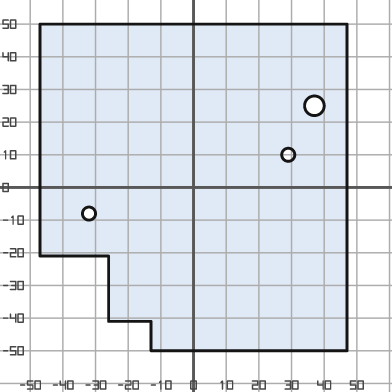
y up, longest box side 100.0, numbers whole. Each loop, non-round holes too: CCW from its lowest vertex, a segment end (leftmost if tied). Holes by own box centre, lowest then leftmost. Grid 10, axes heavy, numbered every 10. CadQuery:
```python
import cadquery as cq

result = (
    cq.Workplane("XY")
    .moveTo(-13.0, -50.0)
    .lineTo(47.0, -50.0)
    .lineTo(47.0, 50.0)
    .lineTo(-47.0, 50.0)
    .lineTo(-47.0, -21.0)
    .lineTo(-26.0, -21.0)
    .lineTo(-26.0, -41.0)
    .lineTo(-13.0, -41.0)
    .close()
    .moveTo(-32.0, -8.0)
    .circle(2.0)
    .moveTo(29.0, 10.0)
    .circle(2.0)
    .moveTo(37.0, 25.0)
    .circle(3.0)
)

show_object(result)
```